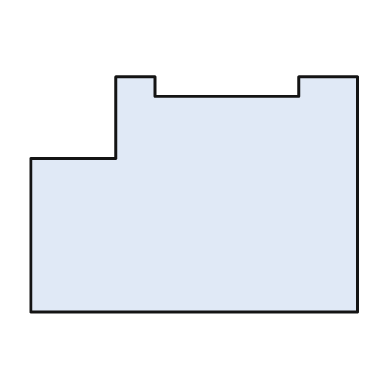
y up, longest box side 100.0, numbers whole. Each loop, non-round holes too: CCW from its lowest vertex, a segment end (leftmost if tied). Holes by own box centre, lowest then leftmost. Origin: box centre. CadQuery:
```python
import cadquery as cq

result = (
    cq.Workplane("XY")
    .moveTo(-50.0, -36.0)
    .lineTo(50.0, -36.0)
    .lineTo(50.0, 36.0)
    .lineTo(32.0, 36.0)
    .lineTo(32.0, 30.0)
    .lineTo(-12.0, 30.0)
    .lineTo(-12.0, 36.0)
    .lineTo(-24.0, 36.0)
    .lineTo(-24.0, 11.0)
    .lineTo(-50.0, 11.0)
    .close()
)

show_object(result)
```